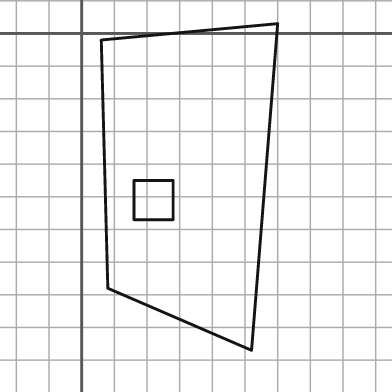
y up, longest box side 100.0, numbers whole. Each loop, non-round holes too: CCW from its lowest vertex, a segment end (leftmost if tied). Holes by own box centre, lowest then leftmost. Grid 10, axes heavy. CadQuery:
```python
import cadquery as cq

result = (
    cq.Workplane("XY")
    .moveTo(52.0, -97.0)
    .lineTo(60.0, 3.0)
    .lineTo(6.0, -2.0)
    .lineTo(8.0, -78.0)
    .close()
    .moveTo(16.0, -57.0)
    .lineTo(28.0, -57.0)
    .lineTo(28.0, -45.0)
    .lineTo(16.0, -45.0)
    .close()
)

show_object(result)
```